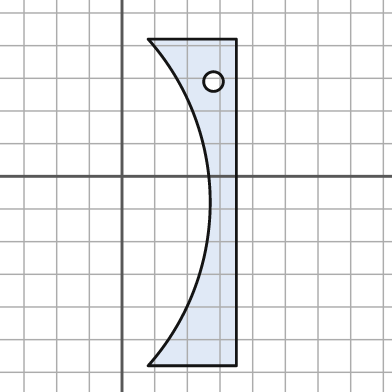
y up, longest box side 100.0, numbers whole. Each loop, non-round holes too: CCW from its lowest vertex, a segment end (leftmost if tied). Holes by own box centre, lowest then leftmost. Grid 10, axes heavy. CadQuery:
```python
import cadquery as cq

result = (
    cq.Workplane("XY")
    .moveTo(8.0, -58.0)
    .lineTo(35.0, -58.0)
    .lineTo(35.0, 42.0)
    .lineTo(8.0, 42.0)
    .threePointArc((27.0, -8.0), (8.0, -58.0))
    .close()
    .moveTo(28.0, 29.0)
    .circle(3.0)
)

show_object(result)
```